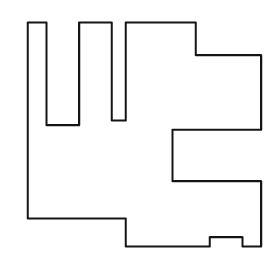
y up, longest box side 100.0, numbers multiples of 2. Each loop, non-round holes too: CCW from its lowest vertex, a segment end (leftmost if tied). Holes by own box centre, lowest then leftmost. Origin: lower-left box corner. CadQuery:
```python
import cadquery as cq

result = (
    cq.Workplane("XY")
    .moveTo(42.0, 0.0)
    .lineTo(78.0, 0.0)
    .lineTo(78.0, 4.0)
    .lineTo(92.0, 4.0)
    .lineTo(92.0, 0.0)
    .lineTo(100.0, 0.0)
    .lineTo(100.0, 28.0)
    .lineTo(62.0, 28.0)
    .lineTo(62.0, 50.0)
    .lineTo(100.0, 50.0)
    .lineTo(100.0, 82.0)
    .lineTo(72.0, 82.0)
    .lineTo(72.0, 96.0)
    .lineTo(42.0, 96.0)
    .lineTo(42.0, 54.0)
    .lineTo(36.0, 54.0)
    .lineTo(36.0, 96.0)
    .lineTo(22.0, 96.0)
    .lineTo(22.0, 52.0)
    .lineTo(8.0, 52.0)
    .lineTo(8.0, 96.0)
    .lineTo(0.0, 96.0)
    .lineTo(0.0, 12.0)
    .lineTo(42.0, 12.0)
    .close()
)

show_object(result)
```